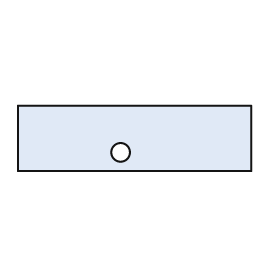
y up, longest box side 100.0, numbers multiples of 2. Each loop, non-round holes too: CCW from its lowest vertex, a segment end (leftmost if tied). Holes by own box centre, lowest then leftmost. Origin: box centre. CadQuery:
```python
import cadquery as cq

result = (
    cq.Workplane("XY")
    .moveTo(-50.0, -14.0)
    .lineTo(50.0, -14.0)
    .lineTo(50.0, 14.0)
    .lineTo(-50.0, 14.0)
    .close()
    .moveTo(-6.0, -6.0)
    .circle(4.0)
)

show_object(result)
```